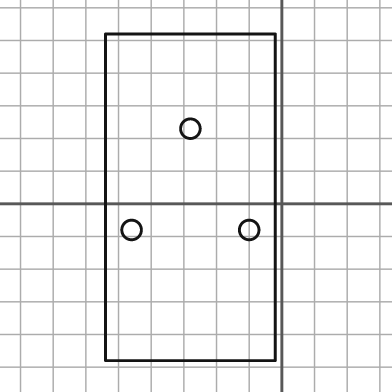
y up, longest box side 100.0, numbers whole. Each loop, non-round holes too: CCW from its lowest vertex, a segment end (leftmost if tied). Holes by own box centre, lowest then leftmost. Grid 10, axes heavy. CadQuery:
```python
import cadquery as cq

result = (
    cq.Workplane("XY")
    .moveTo(-54.0, -48.0)
    .lineTo(-2.0, -48.0)
    .lineTo(-2.0, 52.0)
    .lineTo(-54.0, 52.0)
    .close()
    .moveTo(-46.0, -8.0)
    .circle(3.0)
    .moveTo(-10.0, -8.0)
    .circle(3.0)
    .moveTo(-28.0, 23.0)
    .circle(3.0)
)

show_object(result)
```